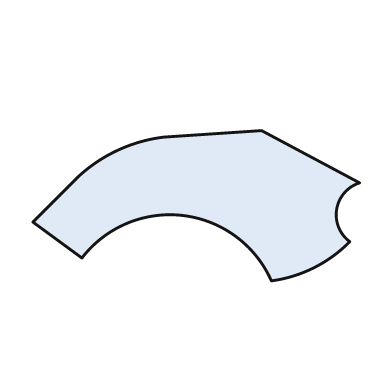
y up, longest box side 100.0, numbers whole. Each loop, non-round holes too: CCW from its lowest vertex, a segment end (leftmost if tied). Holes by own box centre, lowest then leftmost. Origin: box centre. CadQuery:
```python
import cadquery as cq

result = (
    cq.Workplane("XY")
    .moveTo(23.0, -23.0)
    .threePointArc((36.0, -19.0), (47.0, -11.0))
    .threePointArc((43.0, -1.0), (50.0, 7.0))
    .lineTo(20.0, 23.0)
    .lineTo(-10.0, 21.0)
    .threePointArc((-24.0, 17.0), (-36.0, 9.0))
    .lineTo(-50.0, -5.0)
    .lineTo(-35.0, -16.0)
    .threePointArc((-4.0, -3.0), (23.0, -23.0))
    .close()
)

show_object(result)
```